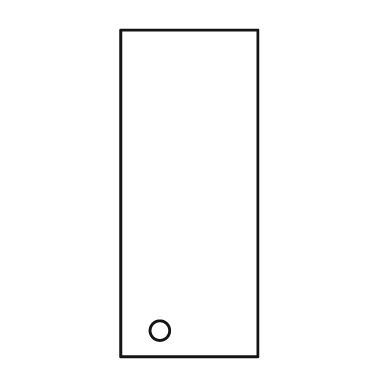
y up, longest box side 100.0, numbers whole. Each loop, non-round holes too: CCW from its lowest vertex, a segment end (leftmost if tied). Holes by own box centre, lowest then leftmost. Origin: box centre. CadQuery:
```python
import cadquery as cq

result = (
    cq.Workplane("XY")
    .moveTo(-21.0, -50.0)
    .lineTo(21.0, -50.0)
    .lineTo(21.0, 50.0)
    .lineTo(-21.0, 50.0)
    .close()
    .moveTo(-9.0, -42.0)
    .circle(3.0)
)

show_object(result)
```